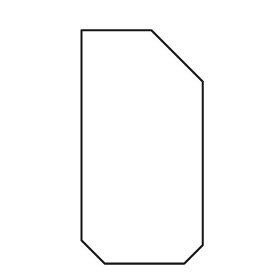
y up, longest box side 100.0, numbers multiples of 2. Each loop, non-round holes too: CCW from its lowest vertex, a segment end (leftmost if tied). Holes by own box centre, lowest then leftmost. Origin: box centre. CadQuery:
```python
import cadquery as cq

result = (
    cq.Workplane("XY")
    .moveTo(-16.0, -50.0)
    .lineTo(18.0, -50.0)
    .lineTo(26.0, -42.0)
    .lineTo(26.0, 28.0)
    .lineTo(4.0, 50.0)
    .lineTo(-26.0, 50.0)
    .lineTo(-26.0, -40.0)
    .close()
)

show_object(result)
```